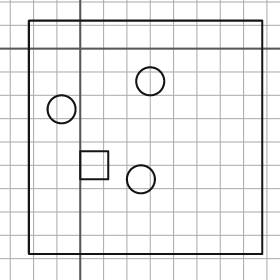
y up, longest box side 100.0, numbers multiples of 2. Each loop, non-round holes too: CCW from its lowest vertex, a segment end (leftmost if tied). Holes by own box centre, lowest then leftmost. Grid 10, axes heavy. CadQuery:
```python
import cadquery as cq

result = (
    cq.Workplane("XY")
    .moveTo(-22.0, -88.0)
    .lineTo(78.0, -88.0)
    .lineTo(78.0, 12.0)
    .lineTo(-22.0, 12.0)
    .close()
    .moveTo(26.0, -56.0)
    .circle(6.0)
    .moveTo(0.0, -56.0)
    .lineTo(12.0, -56.0)
    .lineTo(12.0, -44.0)
    .lineTo(0.0, -44.0)
    .close()
    .moveTo(-8.0, -26.0)
    .circle(6.0)
    .moveTo(30.0, -14.0)
    .circle(6.0)
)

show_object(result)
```